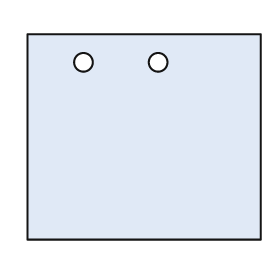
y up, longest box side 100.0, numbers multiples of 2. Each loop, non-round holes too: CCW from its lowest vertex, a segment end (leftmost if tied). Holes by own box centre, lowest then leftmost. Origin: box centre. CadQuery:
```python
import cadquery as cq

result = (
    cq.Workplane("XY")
    .moveTo(-50.0, -44.0)
    .lineTo(50.0, -44.0)
    .lineTo(50.0, 44.0)
    .lineTo(-50.0, 44.0)
    .close()
    .moveTo(-26.0, 32.0)
    .circle(4.0)
    .moveTo(6.0, 32.0)
    .circle(4.0)
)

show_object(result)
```